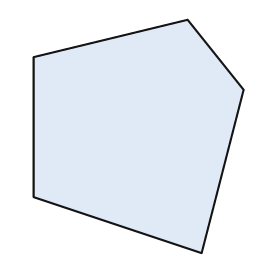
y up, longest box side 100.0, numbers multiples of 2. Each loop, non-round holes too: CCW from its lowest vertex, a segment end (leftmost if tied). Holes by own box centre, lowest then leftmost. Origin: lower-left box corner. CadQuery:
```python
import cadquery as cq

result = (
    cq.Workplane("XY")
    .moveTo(72.0, 0.0)
    .lineTo(90.0, 70.0)
    .lineTo(66.0, 100.0)
    .lineTo(0.0, 84.0)
    .lineTo(0.0, 24.0)
    .close()
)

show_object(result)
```